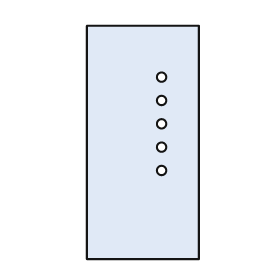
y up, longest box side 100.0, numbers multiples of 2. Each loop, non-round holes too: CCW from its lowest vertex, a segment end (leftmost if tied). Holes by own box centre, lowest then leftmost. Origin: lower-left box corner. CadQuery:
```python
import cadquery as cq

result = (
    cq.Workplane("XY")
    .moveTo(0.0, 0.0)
    .lineTo(48.0, 0.0)
    .lineTo(48.0, 100.0)
    .lineTo(0.0, 100.0)
    .close()
    .moveTo(32.0, 38.0)
    .circle(2.0)
    .moveTo(32.0, 48.0)
    .circle(2.0)
    .moveTo(32.0, 58.0)
    .circle(2.0)
    .moveTo(32.0, 68.0)
    .circle(2.0)
    .moveTo(32.0, 78.0)
    .circle(2.0)
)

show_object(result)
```